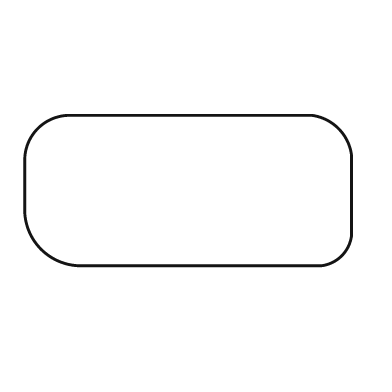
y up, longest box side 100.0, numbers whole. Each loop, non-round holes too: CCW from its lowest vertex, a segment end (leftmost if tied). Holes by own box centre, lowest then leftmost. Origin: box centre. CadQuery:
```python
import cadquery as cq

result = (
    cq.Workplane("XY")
    .moveTo(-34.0, -23.0)
    .lineTo(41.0, -23.0)
    .threePointArc((47.0, -20.0), (50.0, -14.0))
    .lineTo(50.0, 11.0)
    .threePointArc((46.0, 19.0), (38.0, 23.0))
    .lineTo(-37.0, 23.0)
    .threePointArc((-46.0, 19.0), (-50.0, 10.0))
    .lineTo(-50.0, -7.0)
    .threePointArc((-45.0, -18.0), (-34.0, -23.0))
    .close()
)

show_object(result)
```